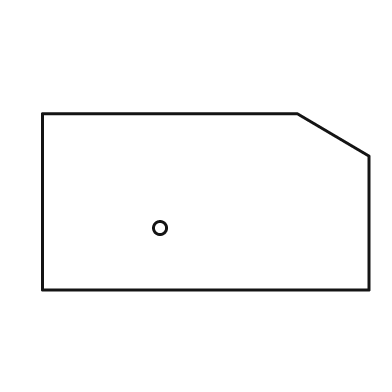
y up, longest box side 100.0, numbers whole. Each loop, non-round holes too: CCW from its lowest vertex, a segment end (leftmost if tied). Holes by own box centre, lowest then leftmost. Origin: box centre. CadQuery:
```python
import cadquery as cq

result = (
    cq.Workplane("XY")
    .moveTo(-50.0, -27.0)
    .lineTo(50.0, -27.0)
    .lineTo(50.0, 14.0)
    .lineTo(28.0, 27.0)
    .lineTo(-50.0, 27.0)
    .close()
    .moveTo(-14.0, -8.0)
    .circle(2.0)
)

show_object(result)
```